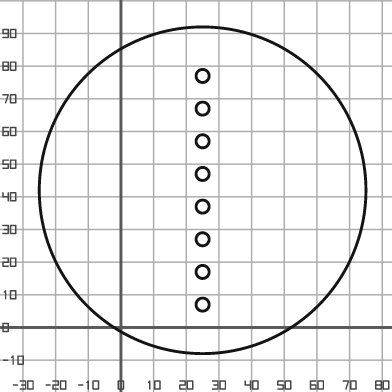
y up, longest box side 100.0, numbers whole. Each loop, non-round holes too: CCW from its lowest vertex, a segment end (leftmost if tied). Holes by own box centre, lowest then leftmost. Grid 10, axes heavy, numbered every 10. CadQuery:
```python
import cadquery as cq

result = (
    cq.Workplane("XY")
    .moveTo(25.0, 42.0)
    .circle(50.0)
    .moveTo(25.0, 7.0)
    .circle(2.0)
    .moveTo(25.0, 17.0)
    .circle(2.0)
    .moveTo(25.0, 27.0)
    .circle(2.0)
    .moveTo(25.0, 37.0)
    .circle(2.0)
    .moveTo(25.0, 47.0)
    .circle(2.0)
    .moveTo(25.0, 57.0)
    .circle(2.0)
    .moveTo(25.0, 67.0)
    .circle(2.0)
    .moveTo(25.0, 77.0)
    .circle(2.0)
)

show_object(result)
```